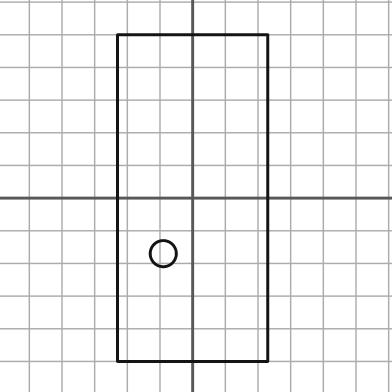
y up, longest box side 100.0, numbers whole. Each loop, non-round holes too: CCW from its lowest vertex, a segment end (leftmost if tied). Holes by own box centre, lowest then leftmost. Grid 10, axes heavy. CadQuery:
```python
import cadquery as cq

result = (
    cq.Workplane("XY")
    .moveTo(-23.0, -50.0)
    .lineTo(23.0, -50.0)
    .lineTo(23.0, 50.0)
    .lineTo(-23.0, 50.0)
    .close()
    .moveTo(-9.0, -17.0)
    .circle(4.0)
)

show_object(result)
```